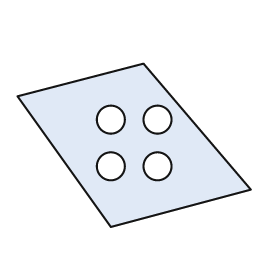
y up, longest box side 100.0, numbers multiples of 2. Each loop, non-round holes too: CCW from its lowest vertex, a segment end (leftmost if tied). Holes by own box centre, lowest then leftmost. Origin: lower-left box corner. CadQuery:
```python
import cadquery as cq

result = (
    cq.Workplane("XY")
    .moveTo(40.0, 0.0)
    .lineTo(100.0, 16.0)
    .lineTo(54.0, 70.0)
    .lineTo(0.0, 56.0)
    .close()
    .moveTo(40.0, 26.0)
    .circle(6.0)
    .moveTo(60.0, 26.0)
    .circle(6.0)
    .moveTo(40.0, 46.0)
    .circle(6.0)
    .moveTo(60.0, 46.0)
    .circle(6.0)
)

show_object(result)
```